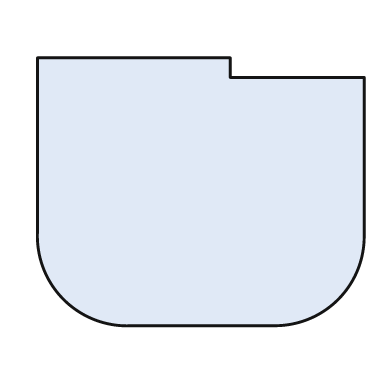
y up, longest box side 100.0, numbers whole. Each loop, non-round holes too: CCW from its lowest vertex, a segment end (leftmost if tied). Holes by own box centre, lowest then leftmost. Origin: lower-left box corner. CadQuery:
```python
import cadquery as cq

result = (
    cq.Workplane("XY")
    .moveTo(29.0, 0.0)
    .lineTo(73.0, 0.0)
    .threePointArc((92.0, 8.0), (100.0, 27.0))
    .lineTo(100.0, 76.0)
    .lineTo(59.0, 76.0)
    .lineTo(59.0, 82.0)
    .lineTo(0.0, 82.0)
    .lineTo(0.0, 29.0)
    .threePointArc((8.0, 8.0), (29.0, 0.0))
    .close()
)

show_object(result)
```